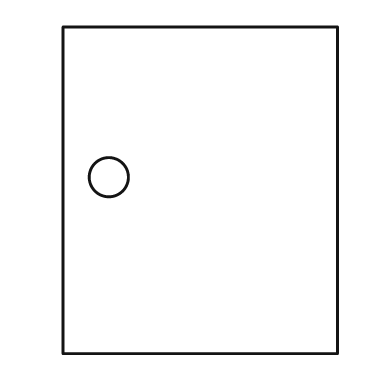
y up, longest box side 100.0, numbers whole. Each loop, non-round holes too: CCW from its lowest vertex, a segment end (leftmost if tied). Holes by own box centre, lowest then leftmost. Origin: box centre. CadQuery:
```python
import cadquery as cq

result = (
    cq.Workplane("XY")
    .moveTo(-42.0, -50.0)
    .lineTo(42.0, -50.0)
    .lineTo(42.0, 50.0)
    .lineTo(-42.0, 50.0)
    .close()
    .moveTo(-28.0, 4.0)
    .circle(6.0)
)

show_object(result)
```